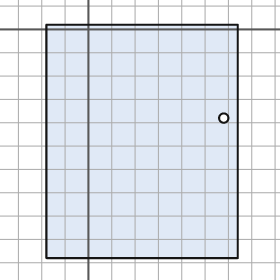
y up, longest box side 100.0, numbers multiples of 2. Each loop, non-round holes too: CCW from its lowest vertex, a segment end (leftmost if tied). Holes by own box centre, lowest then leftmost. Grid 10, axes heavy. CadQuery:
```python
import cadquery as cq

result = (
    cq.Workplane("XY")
    .moveTo(-18.0, -98.0)
    .lineTo(64.0, -98.0)
    .lineTo(64.0, 2.0)
    .lineTo(-18.0, 2.0)
    .close()
    .moveTo(58.0, -38.0)
    .circle(2.0)
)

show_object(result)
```